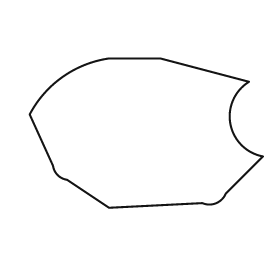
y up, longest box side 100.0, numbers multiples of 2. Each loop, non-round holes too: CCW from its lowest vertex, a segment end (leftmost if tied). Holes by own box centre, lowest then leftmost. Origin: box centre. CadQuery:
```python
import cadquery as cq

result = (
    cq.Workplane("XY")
    .moveTo(-16.0, -32.0)
    .lineTo(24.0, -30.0)
    .threePointArc((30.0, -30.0), (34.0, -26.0))
    .lineTo(50.0, -10.0)
    .threePointArc((36.0, 4.0), (44.0, 22.0))
    .lineTo(6.0, 32.0)
    .lineTo(-16.0, 32.0)
    .threePointArc((-36.0, 24.0), (-50.0, 8.0))
    .lineTo(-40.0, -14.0)
    .threePointArc((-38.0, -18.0), (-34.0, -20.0))
    .close()
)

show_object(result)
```